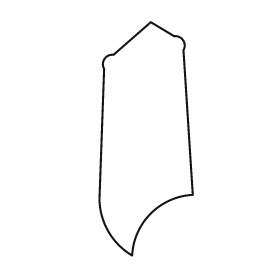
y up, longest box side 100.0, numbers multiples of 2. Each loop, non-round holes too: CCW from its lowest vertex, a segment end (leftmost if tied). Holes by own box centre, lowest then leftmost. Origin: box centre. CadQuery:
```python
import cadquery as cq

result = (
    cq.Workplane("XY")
    .moveTo(-6.0, -50.0)
    .threePointArc((2.0, -32.0), (20.0, -24.0))
    .lineTo(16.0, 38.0)
    .threePointArc((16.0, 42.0), (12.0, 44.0))
    .lineTo(2.0, 50.0)
    .lineTo(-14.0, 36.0)
    .threePointArc((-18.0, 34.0), (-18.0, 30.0))
    .lineTo(-20.0, -26.0)
    .threePointArc((-16.0, -40.0), (-6.0, -50.0))
    .close()
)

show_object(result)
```